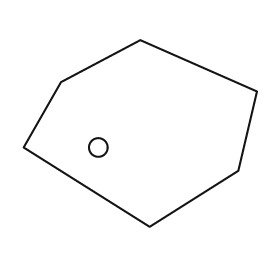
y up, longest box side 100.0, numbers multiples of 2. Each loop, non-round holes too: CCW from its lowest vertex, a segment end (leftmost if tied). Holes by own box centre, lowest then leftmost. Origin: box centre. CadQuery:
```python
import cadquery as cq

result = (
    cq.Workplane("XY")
    .moveTo(4.0, -40.0)
    .lineTo(42.0, -16.0)
    .lineTo(50.0, 18.0)
    .lineTo(0.0, 40.0)
    .lineTo(-34.0, 22.0)
    .lineTo(-50.0, -6.0)
    .close()
    .moveTo(-18.0, -6.0)
    .circle(4.0)
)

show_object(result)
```